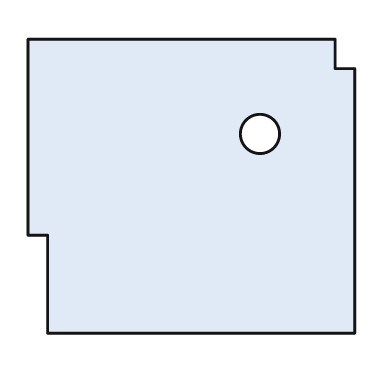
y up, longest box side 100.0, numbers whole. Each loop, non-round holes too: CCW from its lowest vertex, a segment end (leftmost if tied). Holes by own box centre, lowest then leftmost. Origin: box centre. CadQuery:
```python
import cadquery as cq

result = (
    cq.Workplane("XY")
    .moveTo(-44.0, -45.0)
    .lineTo(50.0, -45.0)
    .lineTo(50.0, 36.0)
    .lineTo(44.0, 36.0)
    .lineTo(44.0, 45.0)
    .lineTo(-50.0, 45.0)
    .lineTo(-50.0, -15.0)
    .lineTo(-44.0, -15.0)
    .close()
    .moveTo(21.0, 16.0)
    .circle(6.0)
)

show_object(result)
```